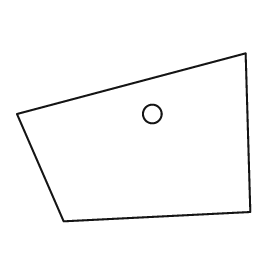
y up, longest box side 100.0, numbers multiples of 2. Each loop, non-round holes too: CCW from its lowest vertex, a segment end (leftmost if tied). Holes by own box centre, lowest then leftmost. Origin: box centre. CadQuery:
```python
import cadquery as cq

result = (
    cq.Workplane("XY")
    .moveTo(-30.0, -36.0)
    .lineTo(50.0, -32.0)
    .lineTo(48.0, 36.0)
    .lineTo(-50.0, 10.0)
    .close()
    .moveTo(8.0, 10.0)
    .circle(4.0)
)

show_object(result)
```